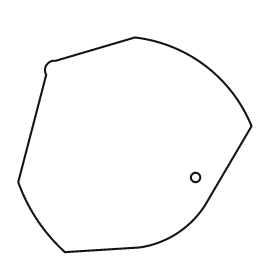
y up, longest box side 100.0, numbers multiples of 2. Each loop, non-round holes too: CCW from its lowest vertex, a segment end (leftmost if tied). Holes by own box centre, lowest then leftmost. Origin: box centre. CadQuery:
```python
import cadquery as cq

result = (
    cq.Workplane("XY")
    .moveTo(-30.0, -46.0)
    .lineTo(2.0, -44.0)
    .threePointArc((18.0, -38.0), (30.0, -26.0))
    .lineTo(50.0, 8.0)
    .threePointArc((30.0, 34.0), (0.0, 46.0))
    .lineTo(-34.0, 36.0)
    .threePointArc((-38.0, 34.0), (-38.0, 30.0))
    .lineTo(-50.0, -16.0)
    .threePointArc((-42.0, -32.0), (-30.0, -46.0))
    .close()
    .moveTo(26.0, -14.0)
    .circle(2.0)
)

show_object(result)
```